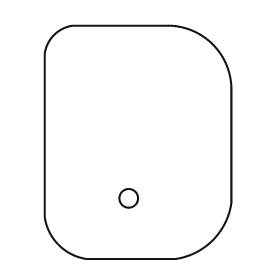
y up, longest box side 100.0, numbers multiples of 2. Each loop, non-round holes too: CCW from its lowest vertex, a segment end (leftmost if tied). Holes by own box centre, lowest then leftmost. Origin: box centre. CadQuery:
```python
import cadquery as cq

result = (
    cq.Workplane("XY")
    .moveTo(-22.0, -50.0)
    .lineTo(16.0, -50.0)
    .threePointArc((32.0, -42.0), (40.0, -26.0))
    .lineTo(40.0, 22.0)
    .threePointArc((32.0, 42.0), (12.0, 50.0))
    .lineTo(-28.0, 50.0)
    .threePointArc((-36.0, 46.0), (-40.0, 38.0))
    .lineTo(-40.0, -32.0)
    .threePointArc((-34.0, -44.0), (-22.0, -50.0))
    .close()
    .moveTo(-4.0, -24.0)
    .circle(4.0)
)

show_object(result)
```